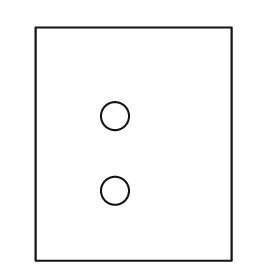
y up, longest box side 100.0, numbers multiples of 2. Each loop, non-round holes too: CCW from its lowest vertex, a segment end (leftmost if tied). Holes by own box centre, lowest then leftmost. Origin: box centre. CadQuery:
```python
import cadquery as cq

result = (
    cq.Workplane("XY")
    .moveTo(-42.0, -50.0)
    .lineTo(42.0, -50.0)
    .lineTo(42.0, 50.0)
    .lineTo(-42.0, 50.0)
    .close()
    .moveTo(-8.0, -20.0)
    .circle(6.0)
    .moveTo(-8.0, 12.0)
    .circle(6.0)
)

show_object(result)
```